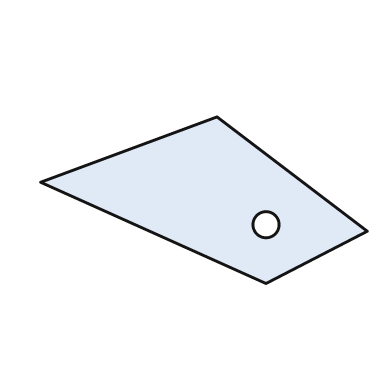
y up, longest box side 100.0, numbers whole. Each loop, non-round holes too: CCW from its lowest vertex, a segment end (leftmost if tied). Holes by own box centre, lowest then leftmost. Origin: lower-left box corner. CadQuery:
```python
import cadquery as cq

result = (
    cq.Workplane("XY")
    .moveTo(69.0, 0.0)
    .lineTo(100.0, 16.0)
    .lineTo(54.0, 51.0)
    .lineTo(0.0, 31.0)
    .close()
    .moveTo(69.0, 18.0)
    .circle(4.0)
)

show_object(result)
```